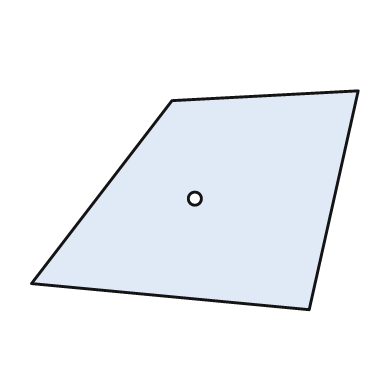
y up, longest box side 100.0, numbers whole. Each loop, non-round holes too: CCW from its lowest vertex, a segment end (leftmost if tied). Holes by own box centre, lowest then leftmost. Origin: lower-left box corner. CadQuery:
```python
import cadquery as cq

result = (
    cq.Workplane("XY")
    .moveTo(85.0, 0.0)
    .lineTo(100.0, 67.0)
    .lineTo(43.0, 64.0)
    .lineTo(0.0, 8.0)
    .close()
    .moveTo(50.0, 34.0)
    .circle(2.0)
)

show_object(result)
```